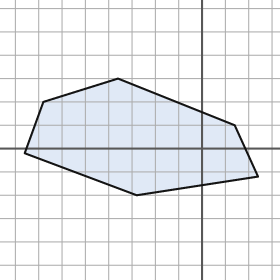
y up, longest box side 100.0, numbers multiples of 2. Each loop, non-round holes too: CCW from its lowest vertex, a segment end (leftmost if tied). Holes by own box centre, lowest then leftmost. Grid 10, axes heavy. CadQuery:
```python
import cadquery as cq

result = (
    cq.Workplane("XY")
    .moveTo(-28.0, -20.0)
    .lineTo(24.0, -12.0)
    .lineTo(14.0, 10.0)
    .lineTo(-36.0, 30.0)
    .lineTo(-68.0, 20.0)
    .lineTo(-76.0, -2.0)
    .close()
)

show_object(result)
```